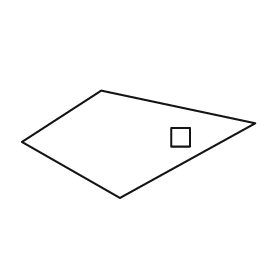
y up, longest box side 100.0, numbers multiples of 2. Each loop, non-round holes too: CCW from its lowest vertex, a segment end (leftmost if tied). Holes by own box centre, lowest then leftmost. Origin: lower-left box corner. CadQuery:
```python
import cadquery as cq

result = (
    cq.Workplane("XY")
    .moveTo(42.0, 0.0)
    .lineTo(100.0, 32.0)
    .lineTo(34.0, 46.0)
    .lineTo(0.0, 24.0)
    .close()
    .moveTo(64.0, 22.0)
    .lineTo(72.0, 22.0)
    .lineTo(72.0, 30.0)
    .lineTo(64.0, 30.0)
    .close()
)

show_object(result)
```